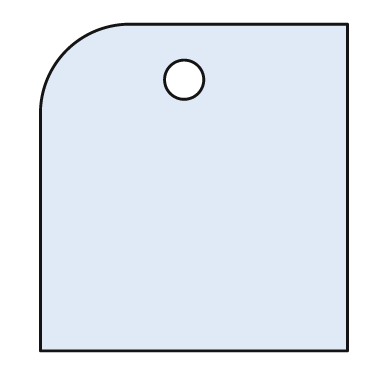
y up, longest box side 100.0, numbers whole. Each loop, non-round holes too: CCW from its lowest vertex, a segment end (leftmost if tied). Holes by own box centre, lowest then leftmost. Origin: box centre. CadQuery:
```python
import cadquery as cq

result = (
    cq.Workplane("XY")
    .moveTo(-47.0, -50.0)
    .lineTo(47.0, -50.0)
    .lineTo(47.0, 50.0)
    .lineTo(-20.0, 50.0)
    .threePointArc((-39.0, 42.0), (-47.0, 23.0))
    .close()
    .moveTo(-3.0, 33.0)
    .circle(6.0)
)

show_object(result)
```